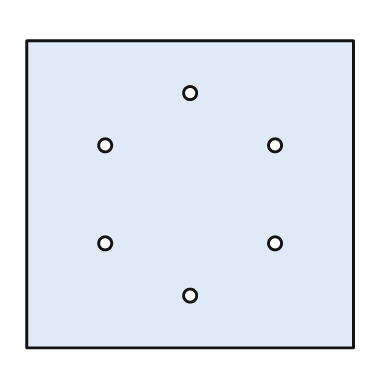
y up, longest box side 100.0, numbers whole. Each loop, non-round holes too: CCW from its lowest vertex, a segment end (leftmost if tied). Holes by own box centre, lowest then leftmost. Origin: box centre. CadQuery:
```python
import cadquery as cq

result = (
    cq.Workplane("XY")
    .moveTo(-50.0, -47.0)
    .lineTo(50.0, -47.0)
    .lineTo(50.0, 47.0)
    .lineTo(-50.0, 47.0)
    .close()
    .moveTo(0.0, -31.0)
    .circle(2.0)
    .moveTo(-26.0, -15.0)
    .circle(2.0)
    .moveTo(26.0, -15.0)
    .circle(2.0)
    .moveTo(-26.0, 15.0)
    .circle(2.0)
    .moveTo(26.0, 15.0)
    .circle(2.0)
    .moveTo(0.0, 31.0)
    .circle(2.0)
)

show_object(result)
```